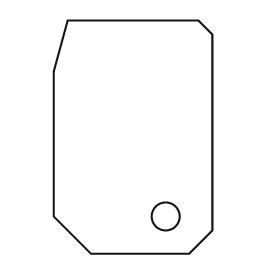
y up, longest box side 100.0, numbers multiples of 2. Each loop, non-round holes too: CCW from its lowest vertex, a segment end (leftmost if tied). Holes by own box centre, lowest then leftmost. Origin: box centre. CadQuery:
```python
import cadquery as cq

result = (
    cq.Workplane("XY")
    .moveTo(-18.0, -50.0)
    .lineTo(24.0, -50.0)
    .lineTo(34.0, -40.0)
    .lineTo(34.0, 44.0)
    .lineTo(28.0, 50.0)
    .lineTo(-28.0, 50.0)
    .lineTo(-34.0, 28.0)
    .lineTo(-34.0, -34.0)
    .close()
    .moveTo(14.0, -34.0)
    .circle(6.0)
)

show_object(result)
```